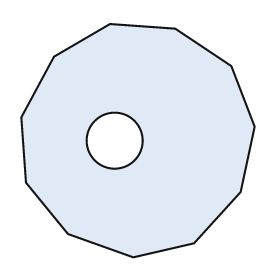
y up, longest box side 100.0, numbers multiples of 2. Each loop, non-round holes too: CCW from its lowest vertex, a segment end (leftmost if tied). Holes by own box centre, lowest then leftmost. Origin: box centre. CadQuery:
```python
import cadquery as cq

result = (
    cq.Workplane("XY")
    .moveTo(-2.0, -50.0)
    .lineTo(24.0, -44.0)
    .lineTo(44.0, -22.0)
    .lineTo(50.0, 6.0)
    .lineTo(40.0, 32.0)
    .lineTo(16.0, 48.0)
    .lineTo(-12.0, 50.0)
    .lineTo(-36.0, 36.0)
    .lineTo(-50.0, 10.0)
    .lineTo(-48.0, -18.0)
    .lineTo(-30.0, -40.0)
    .close()
    .moveTo(-10.0, 0.0)
    .circle(12.0)
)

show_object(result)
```